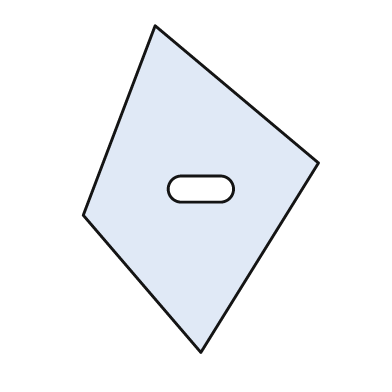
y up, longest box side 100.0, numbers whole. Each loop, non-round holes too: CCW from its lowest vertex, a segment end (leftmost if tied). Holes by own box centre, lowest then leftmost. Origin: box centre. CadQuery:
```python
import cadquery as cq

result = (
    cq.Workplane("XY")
    .moveTo(0.0, -50.0)
    .lineTo(36.0, 8.0)
    .lineTo(-14.0, 50.0)
    .lineTo(-36.0, -8.0)
    .close()
    .moveTo(-6.0, -4.0)
    .lineTo(6.0, -4.0)
    .threePointArc((10.0, 0.0), (6.0, 4.0))
    .lineTo(-6.0, 4.0)
    .threePointArc((-10.0, 0.0), (-6.0, -4.0))
    .close()
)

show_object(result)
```